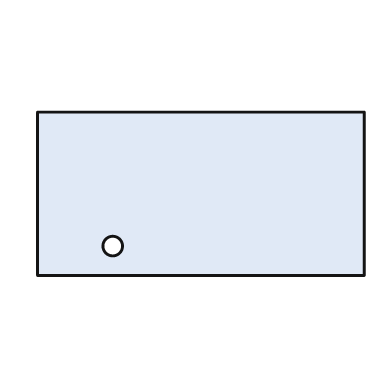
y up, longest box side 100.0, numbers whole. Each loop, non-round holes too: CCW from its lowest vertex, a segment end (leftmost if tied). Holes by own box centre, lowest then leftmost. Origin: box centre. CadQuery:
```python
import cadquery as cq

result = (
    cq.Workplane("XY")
    .moveTo(-50.0, -25.0)
    .lineTo(50.0, -25.0)
    .lineTo(50.0, 25.0)
    .lineTo(-50.0, 25.0)
    .close()
    .moveTo(-27.0, -16.0)
    .circle(3.0)
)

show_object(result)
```